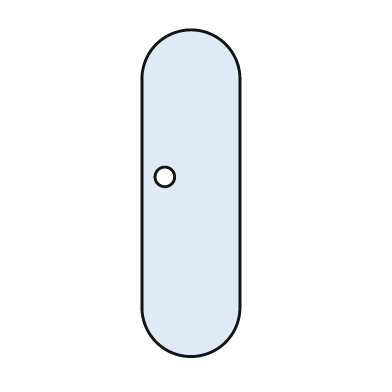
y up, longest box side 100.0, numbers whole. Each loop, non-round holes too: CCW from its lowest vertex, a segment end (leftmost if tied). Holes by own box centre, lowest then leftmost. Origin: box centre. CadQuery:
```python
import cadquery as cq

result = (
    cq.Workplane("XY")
    .moveTo(-15.0, -35.0)
    .threePointArc((0.0, -50.0), (15.0, -35.0))
    .lineTo(15.0, 35.0)
    .threePointArc((0.0, 50.0), (-15.0, 35.0))
    .close()
    .moveTo(-8.0, 5.0)
    .circle(3.0)
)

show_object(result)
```